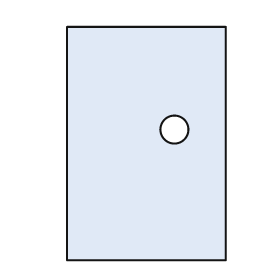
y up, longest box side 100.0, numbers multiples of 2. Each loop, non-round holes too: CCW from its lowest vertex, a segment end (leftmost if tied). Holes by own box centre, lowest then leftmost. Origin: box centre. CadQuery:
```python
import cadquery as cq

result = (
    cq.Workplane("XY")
    .moveTo(-34.0, -50.0)
    .lineTo(34.0, -50.0)
    .lineTo(34.0, 50.0)
    .lineTo(-34.0, 50.0)
    .close()
    .moveTo(12.0, 6.0)
    .circle(6.0)
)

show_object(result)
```